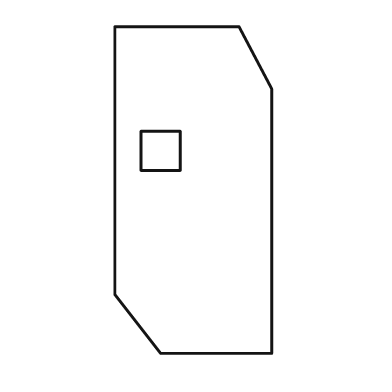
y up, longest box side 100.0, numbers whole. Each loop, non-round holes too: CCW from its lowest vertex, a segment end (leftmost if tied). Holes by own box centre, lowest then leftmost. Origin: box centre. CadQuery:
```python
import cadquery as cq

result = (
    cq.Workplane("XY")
    .moveTo(-10.0, -50.0)
    .lineTo(24.0, -50.0)
    .lineTo(24.0, 31.0)
    .lineTo(14.0, 50.0)
    .lineTo(-24.0, 50.0)
    .lineTo(-24.0, -32.0)
    .close()
    .moveTo(-16.0, 6.0)
    .lineTo(-4.0, 6.0)
    .lineTo(-4.0, 18.0)
    .lineTo(-16.0, 18.0)
    .close()
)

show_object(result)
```